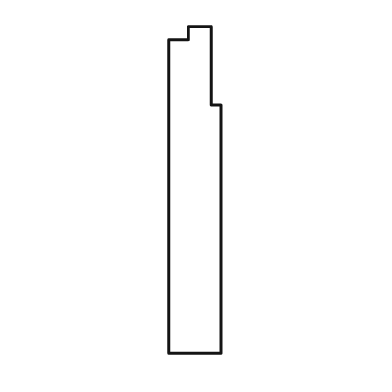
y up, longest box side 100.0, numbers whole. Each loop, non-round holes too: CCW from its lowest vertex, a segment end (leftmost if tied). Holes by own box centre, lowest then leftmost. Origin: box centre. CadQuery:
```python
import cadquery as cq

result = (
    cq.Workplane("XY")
    .moveTo(-8.0, -50.0)
    .lineTo(8.0, -50.0)
    .lineTo(8.0, 26.0)
    .lineTo(5.0, 26.0)
    .lineTo(5.0, 50.0)
    .lineTo(-2.0, 50.0)
    .lineTo(-2.0, 46.0)
    .lineTo(-8.0, 46.0)
    .close()
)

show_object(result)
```